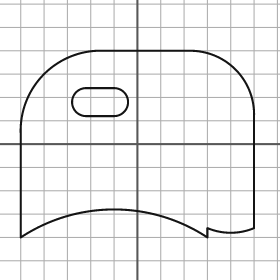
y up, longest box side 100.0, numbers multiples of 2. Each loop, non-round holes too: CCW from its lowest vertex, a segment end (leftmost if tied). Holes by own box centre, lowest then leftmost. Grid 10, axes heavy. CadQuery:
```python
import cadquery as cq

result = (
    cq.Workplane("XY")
    .moveTo(-50.0, -40.0)
    .threePointArc((-10.0, -28.0), (30.0, -40.0))
    .lineTo(30.0, -36.0)
    .threePointArc((40.0, -38.0), (50.0, -36.0))
    .lineTo(50.0, 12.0)
    .threePointArc((42.0, 32.0), (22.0, 40.0))
    .lineTo(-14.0, 40.0)
    .threePointArc((-40.0, 30.0), (-50.0, 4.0))
    .close()
    .moveTo(-22.0, 12.0)
    .lineTo(-10.0, 12.0)
    .threePointArc((-4.0, 18.0), (-10.0, 24.0))
    .lineTo(-22.0, 24.0)
    .threePointArc((-28.0, 18.0), (-22.0, 12.0))
    .close()
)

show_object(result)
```